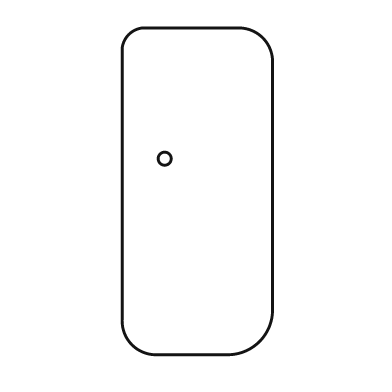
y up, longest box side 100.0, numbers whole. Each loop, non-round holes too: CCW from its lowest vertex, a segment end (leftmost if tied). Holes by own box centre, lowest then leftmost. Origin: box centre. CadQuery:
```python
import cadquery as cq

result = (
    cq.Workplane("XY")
    .moveTo(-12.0, -50.0)
    .lineTo(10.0, -50.0)
    .threePointArc((19.0, -46.0), (23.0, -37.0))
    .lineTo(23.0, 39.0)
    .threePointArc((20.0, 47.0), (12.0, 50.0))
    .lineTo(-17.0, 50.0)
    .threePointArc((-21.0, 48.0), (-23.0, 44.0))
    .lineTo(-23.0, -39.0)
    .threePointArc((-20.0, -47.0), (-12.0, -50.0))
    .close()
    .moveTo(-10.0, 10.0)
    .circle(2.0)
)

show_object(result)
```